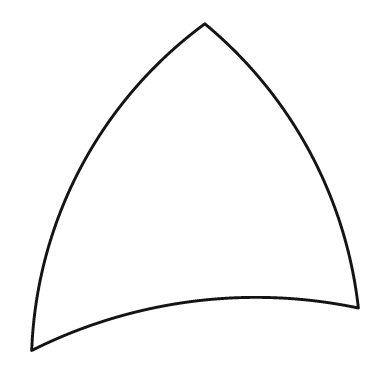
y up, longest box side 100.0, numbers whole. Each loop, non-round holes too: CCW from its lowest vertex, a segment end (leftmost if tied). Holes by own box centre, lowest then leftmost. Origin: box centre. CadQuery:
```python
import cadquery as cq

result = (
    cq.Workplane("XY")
    .moveTo(-50.0, -50.0)
    .threePointArc((-1.0, -35.0), (50.0, -37.0))
    .threePointArc((35.0, 11.0), (3.0, 50.0))
    .threePointArc((-35.0, 6.0), (-50.0, -50.0))
    .close()
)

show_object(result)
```